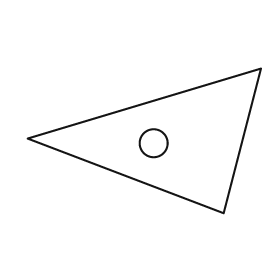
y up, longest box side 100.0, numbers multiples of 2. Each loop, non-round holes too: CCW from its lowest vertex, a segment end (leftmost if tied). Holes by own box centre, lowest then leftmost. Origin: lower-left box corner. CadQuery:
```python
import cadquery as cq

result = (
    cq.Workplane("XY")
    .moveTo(84.0, 0.0)
    .lineTo(100.0, 62.0)
    .lineTo(0.0, 32.0)
    .close()
    .moveTo(54.0, 30.0)
    .circle(6.0)
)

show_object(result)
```